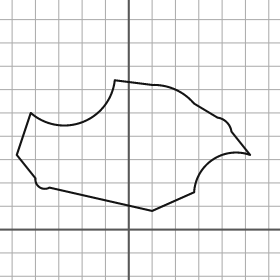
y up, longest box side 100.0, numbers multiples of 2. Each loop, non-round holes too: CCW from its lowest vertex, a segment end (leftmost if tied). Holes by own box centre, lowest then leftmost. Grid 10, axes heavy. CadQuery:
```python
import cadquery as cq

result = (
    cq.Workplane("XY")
    .moveTo(10.0, 8.0)
    .lineTo(28.0, 16.0)
    .threePointArc((36.0, 30.0), (52.0, 32.0))
    .lineTo(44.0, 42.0)
    .threePointArc((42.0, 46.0), (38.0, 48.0))
    .lineTo(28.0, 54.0)
    .threePointArc((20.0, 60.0), (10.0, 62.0))
    .lineTo(-6.0, 64.0)
    .threePointArc((-20.0, 46.0), (-42.0, 50.0))
    .lineTo(-48.0, 32.0)
    .lineTo(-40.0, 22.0)
    .threePointArc((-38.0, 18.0), (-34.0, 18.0))
    .close()
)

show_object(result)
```